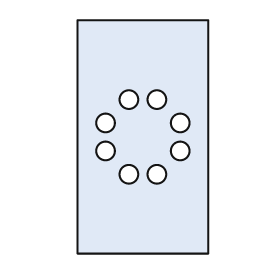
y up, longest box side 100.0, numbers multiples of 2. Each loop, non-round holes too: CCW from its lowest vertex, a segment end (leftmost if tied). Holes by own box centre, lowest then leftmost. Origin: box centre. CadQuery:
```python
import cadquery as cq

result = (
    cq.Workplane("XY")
    .moveTo(-28.0, -50.0)
    .lineTo(28.0, -50.0)
    .lineTo(28.0, 50.0)
    .lineTo(-28.0, 50.0)
    .close()
    .moveTo(-6.0, -16.0)
    .circle(4.0)
    .moveTo(6.0, -16.0)
    .circle(4.0)
    .moveTo(-16.0, -6.0)
    .circle(4.0)
    .moveTo(16.0, -6.0)
    .circle(4.0)
    .moveTo(-16.0, 6.0)
    .circle(4.0)
    .moveTo(16.0, 6.0)
    .circle(4.0)
    .moveTo(-6.0, 16.0)
    .circle(4.0)
    .moveTo(6.0, 16.0)
    .circle(4.0)
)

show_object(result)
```